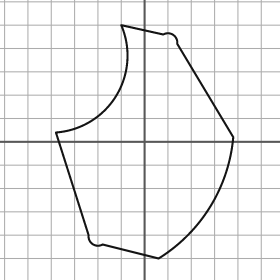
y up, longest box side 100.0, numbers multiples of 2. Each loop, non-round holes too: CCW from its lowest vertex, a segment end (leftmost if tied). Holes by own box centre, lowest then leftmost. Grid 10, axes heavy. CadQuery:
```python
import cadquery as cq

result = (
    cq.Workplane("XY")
    .moveTo(6.0, -50.0)
    .threePointArc((28.0, -28.0), (38.0, 2.0))
    .lineTo(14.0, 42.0)
    .threePointArc((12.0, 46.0), (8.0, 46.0))
    .lineTo(-10.0, 50.0)
    .threePointArc((-12.0, 20.0), (-38.0, 4.0))
    .lineTo(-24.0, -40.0)
    .threePointArc((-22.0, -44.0), (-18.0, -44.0))
    .close()
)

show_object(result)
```